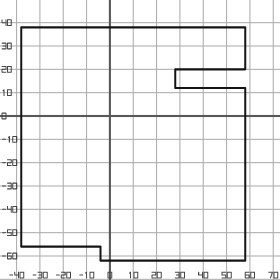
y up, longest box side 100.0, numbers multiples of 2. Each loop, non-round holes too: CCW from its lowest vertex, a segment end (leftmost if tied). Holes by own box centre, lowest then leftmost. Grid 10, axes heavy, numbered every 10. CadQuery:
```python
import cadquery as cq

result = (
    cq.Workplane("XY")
    .moveTo(-4.0, -62.0)
    .lineTo(58.0, -62.0)
    .lineTo(58.0, 12.0)
    .lineTo(28.0, 12.0)
    .lineTo(28.0, 20.0)
    .lineTo(58.0, 20.0)
    .lineTo(58.0, 38.0)
    .lineTo(-38.0, 38.0)
    .lineTo(-38.0, -56.0)
    .lineTo(-4.0, -56.0)
    .close()
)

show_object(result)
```